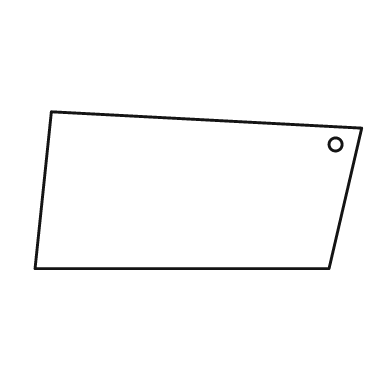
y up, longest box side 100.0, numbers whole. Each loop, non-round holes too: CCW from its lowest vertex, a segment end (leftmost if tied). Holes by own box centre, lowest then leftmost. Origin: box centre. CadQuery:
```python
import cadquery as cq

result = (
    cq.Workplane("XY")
    .moveTo(-50.0, -24.0)
    .lineTo(40.0, -24.0)
    .lineTo(50.0, 19.0)
    .lineTo(-45.0, 24.0)
    .close()
    .moveTo(42.0, 14.0)
    .circle(2.0)
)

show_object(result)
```